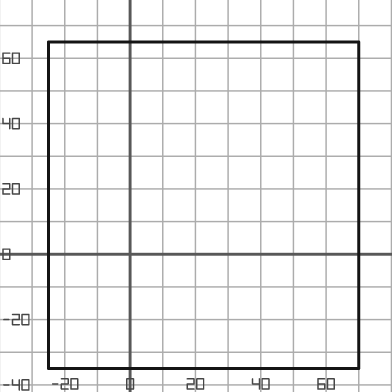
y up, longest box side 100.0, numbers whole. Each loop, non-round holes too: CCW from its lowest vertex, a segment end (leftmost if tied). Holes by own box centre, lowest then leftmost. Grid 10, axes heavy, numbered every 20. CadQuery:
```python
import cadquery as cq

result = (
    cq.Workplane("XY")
    .moveTo(-25.0, -35.0)
    .lineTo(70.0, -35.0)
    .lineTo(70.0, 65.0)
    .lineTo(-25.0, 65.0)
    .close()
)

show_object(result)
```